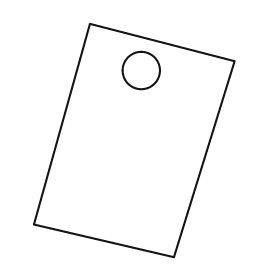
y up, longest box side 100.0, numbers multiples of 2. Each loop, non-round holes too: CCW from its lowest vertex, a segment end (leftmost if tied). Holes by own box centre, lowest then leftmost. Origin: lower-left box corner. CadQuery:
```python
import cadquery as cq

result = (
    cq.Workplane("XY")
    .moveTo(60.0, 0.0)
    .lineTo(86.0, 84.0)
    .lineTo(24.0, 100.0)
    .lineTo(0.0, 14.0)
    .close()
    .moveTo(46.0, 80.0)
    .circle(8.0)
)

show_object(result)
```